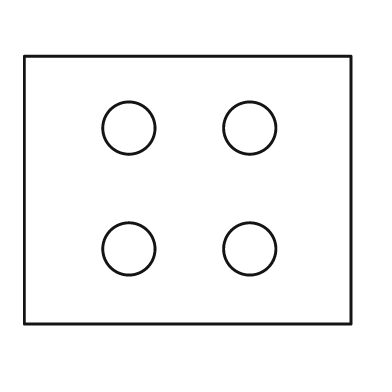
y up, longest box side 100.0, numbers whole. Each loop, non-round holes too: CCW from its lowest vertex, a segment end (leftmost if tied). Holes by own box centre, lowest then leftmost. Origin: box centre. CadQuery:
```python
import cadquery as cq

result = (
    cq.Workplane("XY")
    .moveTo(-50.0, -41.0)
    .lineTo(50.0, -41.0)
    .lineTo(50.0, 41.0)
    .lineTo(-50.0, 41.0)
    .close()
    .moveTo(-18.0, -18.0)
    .circle(8.0)
    .moveTo(19.0, -18.0)
    .circle(8.0)
    .moveTo(-18.0, 19.0)
    .circle(8.0)
    .moveTo(19.0, 19.0)
    .circle(8.0)
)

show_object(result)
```